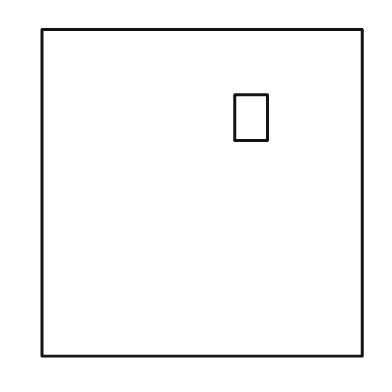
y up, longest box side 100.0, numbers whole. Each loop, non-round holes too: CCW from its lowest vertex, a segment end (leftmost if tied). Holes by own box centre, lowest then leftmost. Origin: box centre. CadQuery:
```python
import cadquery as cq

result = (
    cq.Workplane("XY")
    .moveTo(-49.0, -50.0)
    .lineTo(49.0, -50.0)
    .lineTo(49.0, 50.0)
    .lineTo(-49.0, 50.0)
    .close()
    .moveTo(10.0, 16.0)
    .lineTo(20.0, 16.0)
    .lineTo(20.0, 30.0)
    .lineTo(10.0, 30.0)
    .close()
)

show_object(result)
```